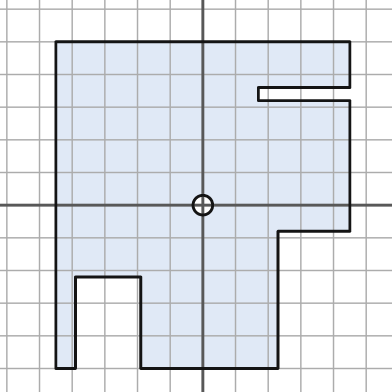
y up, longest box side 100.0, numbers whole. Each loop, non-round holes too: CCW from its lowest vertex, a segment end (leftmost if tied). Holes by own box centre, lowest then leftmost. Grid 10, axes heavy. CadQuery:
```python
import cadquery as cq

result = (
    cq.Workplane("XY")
    .moveTo(-45.0, -50.0)
    .lineTo(-39.0, -50.0)
    .lineTo(-39.0, -22.0)
    .lineTo(-19.0, -22.0)
    .lineTo(-19.0, -50.0)
    .lineTo(23.0, -50.0)
    .lineTo(23.0, -8.0)
    .lineTo(45.0, -8.0)
    .lineTo(45.0, 32.0)
    .lineTo(17.0, 32.0)
    .lineTo(17.0, 36.0)
    .lineTo(45.0, 36.0)
    .lineTo(45.0, 50.0)
    .lineTo(-45.0, 50.0)
    .close()
    .moveTo(0.0, 0.0)
    .circle(3.0)
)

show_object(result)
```